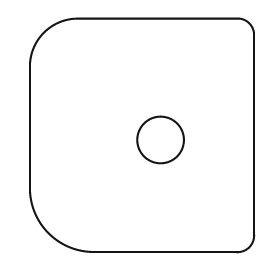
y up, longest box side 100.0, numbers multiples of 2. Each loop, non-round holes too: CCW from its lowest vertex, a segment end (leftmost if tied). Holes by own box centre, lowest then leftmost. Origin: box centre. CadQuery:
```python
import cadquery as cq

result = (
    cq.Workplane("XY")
    .moveTo(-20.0, -50.0)
    .lineTo(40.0, -50.0)
    .threePointArc((46.0, -48.0), (48.0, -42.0))
    .lineTo(48.0, 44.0)
    .threePointArc((46.0, 48.0), (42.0, 50.0))
    .lineTo(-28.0, 50.0)
    .threePointArc((-42.0, 44.0), (-48.0, 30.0))
    .lineTo(-48.0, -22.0)
    .threePointArc((-40.0, -42.0), (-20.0, -50.0))
    .close()
    .moveTo(8.0, -2.0)
    .circle(10.0)
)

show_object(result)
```